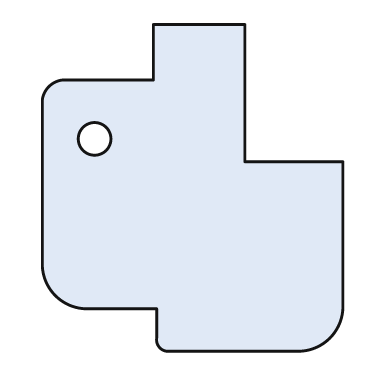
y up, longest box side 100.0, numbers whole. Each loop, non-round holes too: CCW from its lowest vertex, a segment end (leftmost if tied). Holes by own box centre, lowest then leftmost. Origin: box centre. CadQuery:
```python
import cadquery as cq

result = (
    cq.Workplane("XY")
    .moveTo(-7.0, -50.0)
    .lineTo(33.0, -50.0)
    .threePointArc((42.0, -46.0), (46.0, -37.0))
    .lineTo(46.0, 8.0)
    .lineTo(16.0, 8.0)
    .lineTo(16.0, 50.0)
    .lineTo(-12.0, 50.0)
    .lineTo(-12.0, 33.0)
    .lineTo(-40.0, 33.0)
    .threePointArc((-44.0, 31.0), (-46.0, 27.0))
    .lineTo(-46.0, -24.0)
    .threePointArc((-42.0, -33.0), (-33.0, -37.0))
    .lineTo(-11.0, -37.0)
    .lineTo(-11.0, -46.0)
    .threePointArc((-10.0, -49.0), (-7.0, -50.0))
    .close()
    .moveTo(-30.0, 15.0)
    .circle(5.0)
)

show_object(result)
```